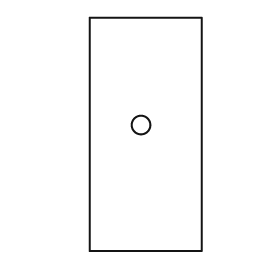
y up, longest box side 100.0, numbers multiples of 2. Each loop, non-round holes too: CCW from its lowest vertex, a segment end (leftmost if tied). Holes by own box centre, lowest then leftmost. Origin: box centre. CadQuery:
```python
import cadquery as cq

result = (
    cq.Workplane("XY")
    .moveTo(-24.0, -50.0)
    .lineTo(24.0, -50.0)
    .lineTo(24.0, 50.0)
    .lineTo(-24.0, 50.0)
    .close()
    .moveTo(-2.0, 4.0)
    .circle(4.0)
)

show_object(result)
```